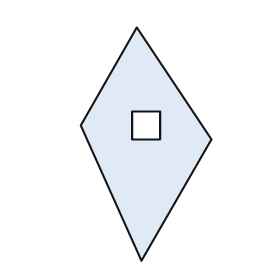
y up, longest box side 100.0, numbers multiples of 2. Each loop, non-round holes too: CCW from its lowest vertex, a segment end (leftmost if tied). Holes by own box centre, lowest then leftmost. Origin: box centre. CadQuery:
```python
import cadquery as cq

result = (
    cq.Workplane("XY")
    .moveTo(-2.0, -50.0)
    .lineTo(28.0, 2.0)
    .lineTo(-4.0, 50.0)
    .lineTo(-28.0, 8.0)
    .close()
    .moveTo(-6.0, 2.0)
    .lineTo(6.0, 2.0)
    .lineTo(6.0, 14.0)
    .lineTo(-6.0, 14.0)
    .close()
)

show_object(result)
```